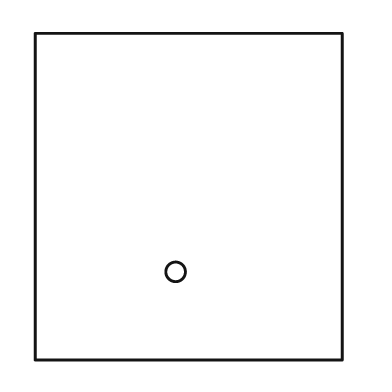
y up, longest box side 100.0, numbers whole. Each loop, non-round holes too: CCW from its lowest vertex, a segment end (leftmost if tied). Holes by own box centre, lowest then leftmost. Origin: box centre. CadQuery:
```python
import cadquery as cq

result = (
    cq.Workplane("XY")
    .moveTo(-47.0, -50.0)
    .lineTo(47.0, -50.0)
    .lineTo(47.0, 50.0)
    .lineTo(-47.0, 50.0)
    .close()
    .moveTo(-4.0, -23.0)
    .circle(3.0)
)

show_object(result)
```